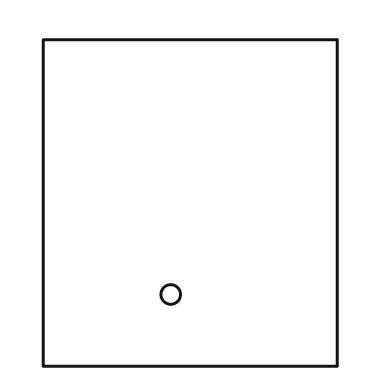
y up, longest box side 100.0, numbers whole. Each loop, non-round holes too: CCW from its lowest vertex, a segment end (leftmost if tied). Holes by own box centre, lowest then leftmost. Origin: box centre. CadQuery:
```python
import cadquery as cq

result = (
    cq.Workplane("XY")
    .moveTo(-45.0, -50.0)
    .lineTo(45.0, -50.0)
    .lineTo(45.0, 50.0)
    .lineTo(-45.0, 50.0)
    .close()
    .moveTo(-6.0, -28.0)
    .circle(3.0)
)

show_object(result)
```